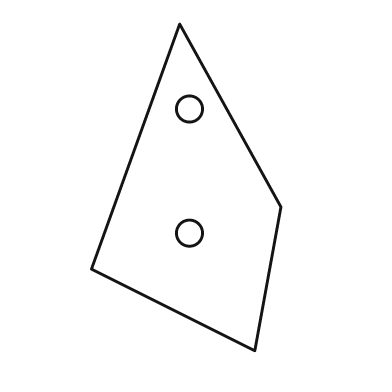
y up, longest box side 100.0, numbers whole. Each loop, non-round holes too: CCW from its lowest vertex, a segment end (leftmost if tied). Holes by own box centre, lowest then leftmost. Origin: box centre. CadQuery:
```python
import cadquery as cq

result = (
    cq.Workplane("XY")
    .moveTo(21.0, -50.0)
    .lineTo(29.0, -6.0)
    .lineTo(-2.0, 50.0)
    .lineTo(-29.0, -25.0)
    .close()
    .moveTo(1.0, -14.0)
    .circle(4.0)
    .moveTo(1.0, 24.0)
    .circle(4.0)
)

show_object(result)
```